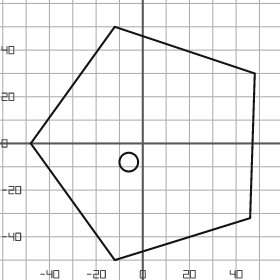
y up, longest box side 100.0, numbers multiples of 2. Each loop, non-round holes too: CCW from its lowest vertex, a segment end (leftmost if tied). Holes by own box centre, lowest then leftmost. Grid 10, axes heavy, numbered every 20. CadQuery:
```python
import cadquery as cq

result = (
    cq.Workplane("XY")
    .moveTo(-12.0, -50.0)
    .lineTo(46.0, -32.0)
    .lineTo(48.0, 30.0)
    .lineTo(-12.0, 50.0)
    .lineTo(-48.0, 0.0)
    .close()
    .moveTo(-6.0, -8.0)
    .circle(4.0)
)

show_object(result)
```